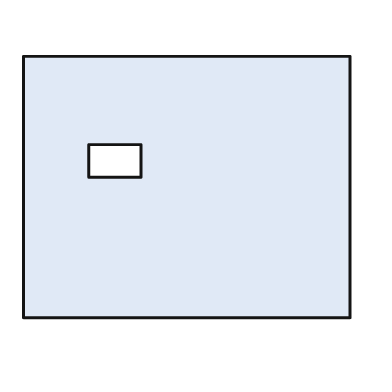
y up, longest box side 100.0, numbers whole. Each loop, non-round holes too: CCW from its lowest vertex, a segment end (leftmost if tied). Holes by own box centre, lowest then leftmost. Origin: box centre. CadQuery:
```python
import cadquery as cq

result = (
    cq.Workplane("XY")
    .moveTo(-50.0, -40.0)
    .lineTo(50.0, -40.0)
    .lineTo(50.0, 40.0)
    .lineTo(-50.0, 40.0)
    .close()
    .moveTo(-30.0, 3.0)
    .lineTo(-14.0, 3.0)
    .lineTo(-14.0, 13.0)
    .lineTo(-30.0, 13.0)
    .close()
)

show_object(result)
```